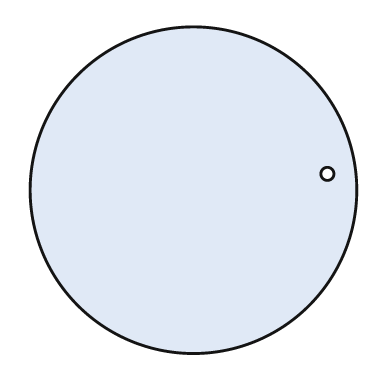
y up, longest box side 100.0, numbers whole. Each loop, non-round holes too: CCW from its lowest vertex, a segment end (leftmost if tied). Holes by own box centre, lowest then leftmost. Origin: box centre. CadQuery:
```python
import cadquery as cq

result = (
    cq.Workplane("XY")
    .moveTo(0.0, 0.0)
    .circle(50.0)
    .moveTo(41.0, 5.0)
    .circle(2.0)
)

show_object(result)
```